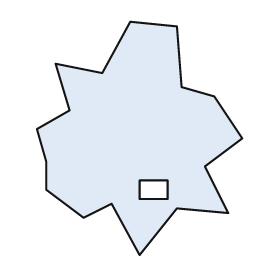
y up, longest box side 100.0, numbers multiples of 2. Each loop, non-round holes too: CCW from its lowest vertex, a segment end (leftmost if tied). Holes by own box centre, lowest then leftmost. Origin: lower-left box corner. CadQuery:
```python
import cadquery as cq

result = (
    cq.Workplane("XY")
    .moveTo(44.0, 0.0)
    .lineTo(60.0, 20.0)
    .lineTo(82.0, 18.0)
    .lineTo(72.0, 38.0)
    .lineTo(88.0, 50.0)
    .lineTo(76.0, 68.0)
    .lineTo(62.0, 72.0)
    .lineTo(60.0, 98.0)
    .lineTo(40.0, 100.0)
    .lineTo(28.0, 78.0)
    .lineTo(8.0, 82.0)
    .lineTo(14.0, 62.0)
    .lineTo(0.0, 54.0)
    .lineTo(4.0, 40.0)
    .lineTo(4.0, 28.0)
    .lineTo(20.0, 16.0)
    .lineTo(32.0, 22.0)
    .close()
    .moveTo(44.0, 24.0)
    .lineTo(56.0, 24.0)
    .lineTo(56.0, 32.0)
    .lineTo(44.0, 32.0)
    .close()
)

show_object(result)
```